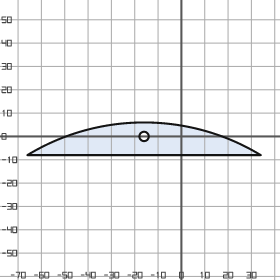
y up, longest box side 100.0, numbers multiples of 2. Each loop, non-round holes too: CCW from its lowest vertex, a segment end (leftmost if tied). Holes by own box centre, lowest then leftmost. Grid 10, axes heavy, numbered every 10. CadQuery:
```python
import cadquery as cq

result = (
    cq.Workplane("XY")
    .moveTo(-66.0, -8.0)
    .lineTo(34.0, -8.0)
    .threePointArc((-16.0, 6.0), (-66.0, -8.0))
    .close()
    .moveTo(-16.0, 0.0)
    .circle(2.0)
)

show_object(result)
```